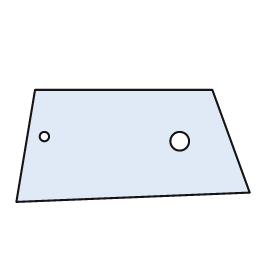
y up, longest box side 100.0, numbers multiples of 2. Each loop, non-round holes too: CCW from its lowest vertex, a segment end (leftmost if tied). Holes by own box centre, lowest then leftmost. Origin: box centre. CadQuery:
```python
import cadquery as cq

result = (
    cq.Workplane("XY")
    .moveTo(-50.0, -24.0)
    .lineTo(50.0, -20.0)
    .lineTo(34.0, 24.0)
    .lineTo(-42.0, 24.0)
    .close()
    .moveTo(20.0, 2.0)
    .circle(4.0)
    .moveTo(-38.0, 4.0)
    .circle(2.0)
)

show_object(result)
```